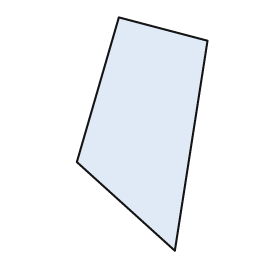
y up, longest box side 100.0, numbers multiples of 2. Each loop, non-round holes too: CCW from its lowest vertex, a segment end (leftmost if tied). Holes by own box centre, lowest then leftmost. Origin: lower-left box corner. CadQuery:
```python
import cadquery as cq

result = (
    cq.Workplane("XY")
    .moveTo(42.0, 0.0)
    .lineTo(56.0, 90.0)
    .lineTo(18.0, 100.0)
    .lineTo(0.0, 38.0)
    .close()
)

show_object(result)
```